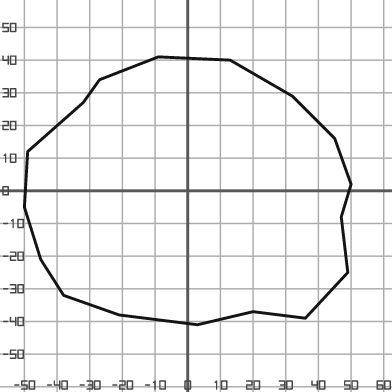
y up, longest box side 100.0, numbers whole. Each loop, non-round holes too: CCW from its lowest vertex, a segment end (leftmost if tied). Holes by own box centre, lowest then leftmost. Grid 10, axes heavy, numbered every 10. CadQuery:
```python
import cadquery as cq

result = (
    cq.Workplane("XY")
    .moveTo(3.0, -41.0)
    .lineTo(20.0, -37.0)
    .lineTo(36.0, -39.0)
    .lineTo(49.0, -25.0)
    .lineTo(47.0, -8.0)
    .lineTo(50.0, 2.0)
    .lineTo(45.0, 16.0)
    .lineTo(32.0, 29.0)
    .lineTo(13.0, 40.0)
    .lineTo(-9.0, 41.0)
    .lineTo(-27.0, 34.0)
    .lineTo(-32.0, 27.0)
    .lineTo(-49.0, 12.0)
    .lineTo(-50.0, -5.0)
    .lineTo(-45.0, -21.0)
    .lineTo(-38.0, -32.0)
    .lineTo(-21.0, -38.0)
    .close()
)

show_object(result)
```